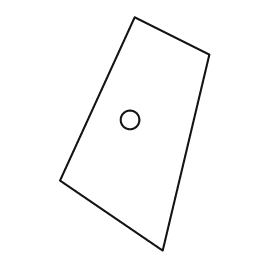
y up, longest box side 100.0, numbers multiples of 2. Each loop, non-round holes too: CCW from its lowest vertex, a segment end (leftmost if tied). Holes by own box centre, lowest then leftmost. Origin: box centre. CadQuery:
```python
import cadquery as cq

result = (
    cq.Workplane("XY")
    .moveTo(12.0, -50.0)
    .lineTo(32.0, 34.0)
    .lineTo(0.0, 50.0)
    .lineTo(-32.0, -20.0)
    .close()
    .moveTo(-2.0, 6.0)
    .circle(4.0)
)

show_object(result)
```